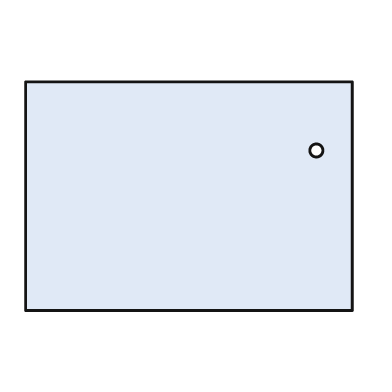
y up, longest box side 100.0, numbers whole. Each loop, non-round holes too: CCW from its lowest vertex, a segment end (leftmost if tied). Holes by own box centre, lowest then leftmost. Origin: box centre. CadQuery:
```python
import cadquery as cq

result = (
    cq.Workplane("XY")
    .moveTo(-50.0, -35.0)
    .lineTo(50.0, -35.0)
    .lineTo(50.0, 35.0)
    .lineTo(-50.0, 35.0)
    .close()
    .moveTo(39.0, 14.0)
    .circle(2.0)
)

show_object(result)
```